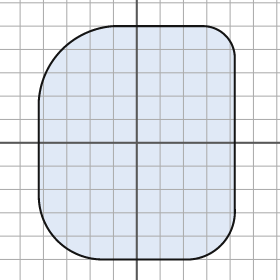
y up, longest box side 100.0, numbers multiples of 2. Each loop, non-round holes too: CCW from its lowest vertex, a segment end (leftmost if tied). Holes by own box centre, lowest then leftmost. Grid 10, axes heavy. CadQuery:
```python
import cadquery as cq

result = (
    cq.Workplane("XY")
    .moveTo(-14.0, -50.0)
    .lineTo(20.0, -50.0)
    .threePointArc((36.0, -44.0), (42.0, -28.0))
    .lineTo(42.0, 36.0)
    .threePointArc((38.0, 46.0), (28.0, 50.0))
    .lineTo(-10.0, 50.0)
    .threePointArc((-32.0, 40.0), (-42.0, 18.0))
    .lineTo(-42.0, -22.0)
    .threePointArc((-34.0, -42.0), (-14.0, -50.0))
    .close()
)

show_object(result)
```